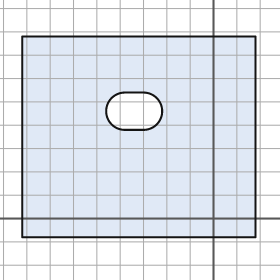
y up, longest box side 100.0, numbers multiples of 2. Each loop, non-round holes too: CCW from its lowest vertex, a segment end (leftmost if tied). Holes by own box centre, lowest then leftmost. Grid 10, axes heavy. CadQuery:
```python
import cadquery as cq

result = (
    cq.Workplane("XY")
    .moveTo(-82.0, -8.0)
    .lineTo(18.0, -8.0)
    .lineTo(18.0, 78.0)
    .lineTo(-82.0, 78.0)
    .close()
    .moveTo(-38.0, 38.0)
    .lineTo(-30.0, 38.0)
    .threePointArc((-22.0, 46.0), (-30.0, 54.0))
    .lineTo(-38.0, 54.0)
    .threePointArc((-46.0, 46.0), (-38.0, 38.0))
    .close()
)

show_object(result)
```